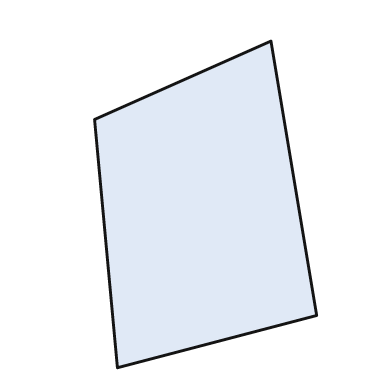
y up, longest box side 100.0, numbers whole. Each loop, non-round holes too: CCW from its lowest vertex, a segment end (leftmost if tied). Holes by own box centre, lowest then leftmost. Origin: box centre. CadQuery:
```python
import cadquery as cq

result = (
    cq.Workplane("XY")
    .moveTo(-27.0, -50.0)
    .lineTo(34.0, -34.0)
    .lineTo(20.0, 50.0)
    .lineTo(-34.0, 26.0)
    .close()
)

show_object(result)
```